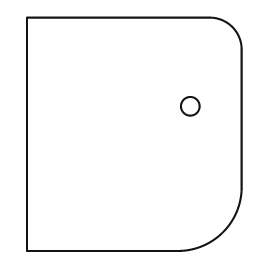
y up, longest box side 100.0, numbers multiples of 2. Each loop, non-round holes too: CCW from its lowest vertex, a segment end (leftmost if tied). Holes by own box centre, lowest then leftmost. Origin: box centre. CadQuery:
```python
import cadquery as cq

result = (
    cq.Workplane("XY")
    .moveTo(-46.0, -50.0)
    .lineTo(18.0, -50.0)
    .threePointArc((38.0, -42.0), (46.0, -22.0))
    .lineTo(46.0, 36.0)
    .threePointArc((42.0, 46.0), (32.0, 50.0))
    .lineTo(-46.0, 50.0)
    .close()
    .moveTo(24.0, 12.0)
    .circle(4.0)
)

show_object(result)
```